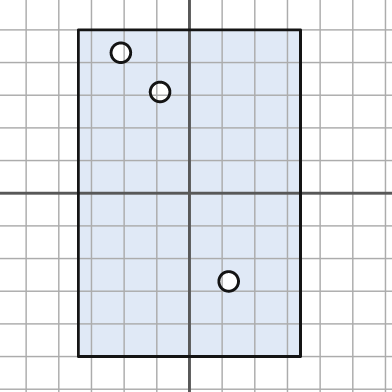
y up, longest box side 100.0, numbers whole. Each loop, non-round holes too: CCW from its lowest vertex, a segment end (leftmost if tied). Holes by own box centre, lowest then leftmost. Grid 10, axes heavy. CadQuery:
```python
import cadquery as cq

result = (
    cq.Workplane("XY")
    .moveTo(-34.0, -50.0)
    .lineTo(34.0, -50.0)
    .lineTo(34.0, 50.0)
    .lineTo(-34.0, 50.0)
    .close()
    .moveTo(12.0, -27.0)
    .circle(3.0)
    .moveTo(-9.0, 31.0)
    .circle(3.0)
    .moveTo(-21.0, 43.0)
    .circle(3.0)
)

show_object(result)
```